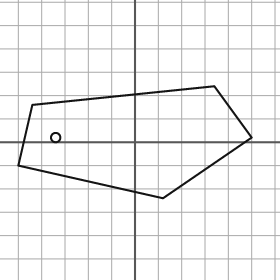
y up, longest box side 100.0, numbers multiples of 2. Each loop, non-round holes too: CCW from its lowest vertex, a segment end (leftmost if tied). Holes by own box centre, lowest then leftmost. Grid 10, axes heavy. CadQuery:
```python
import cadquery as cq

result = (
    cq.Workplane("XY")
    .moveTo(12.0, -24.0)
    .lineTo(50.0, 2.0)
    .lineTo(34.0, 24.0)
    .lineTo(-44.0, 16.0)
    .lineTo(-50.0, -10.0)
    .close()
    .moveTo(-34.0, 2.0)
    .circle(2.0)
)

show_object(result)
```